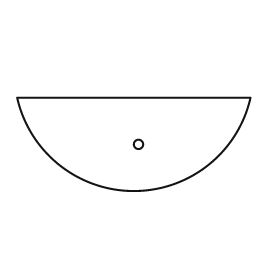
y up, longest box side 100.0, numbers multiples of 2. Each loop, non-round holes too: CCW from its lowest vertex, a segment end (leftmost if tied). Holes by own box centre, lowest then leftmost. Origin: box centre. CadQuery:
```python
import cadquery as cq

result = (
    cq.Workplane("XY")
    .moveTo(-50.0, 20.0)
    .threePointArc((0.0, -20.0), (50.0, 20.0))
    .close()
    .moveTo(2.0, 0.0)
    .circle(2.0)
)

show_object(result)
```